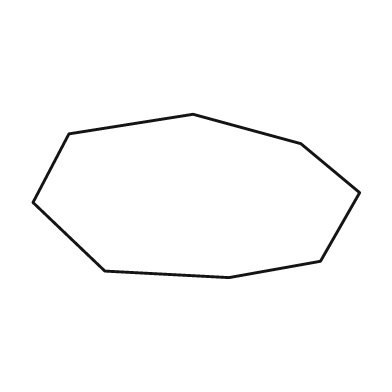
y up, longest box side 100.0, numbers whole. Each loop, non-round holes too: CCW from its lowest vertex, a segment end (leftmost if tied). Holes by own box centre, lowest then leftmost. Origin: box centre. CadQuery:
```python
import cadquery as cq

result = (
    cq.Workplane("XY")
    .moveTo(10.0, -25.0)
    .lineTo(38.0, -20.0)
    .lineTo(50.0, 1.0)
    .lineTo(32.0, 16.0)
    .lineTo(-1.0, 25.0)
    .lineTo(-39.0, 19.0)
    .lineTo(-50.0, -2.0)
    .lineTo(-28.0, -23.0)
    .close()
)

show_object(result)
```